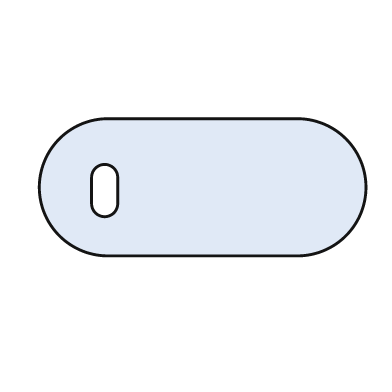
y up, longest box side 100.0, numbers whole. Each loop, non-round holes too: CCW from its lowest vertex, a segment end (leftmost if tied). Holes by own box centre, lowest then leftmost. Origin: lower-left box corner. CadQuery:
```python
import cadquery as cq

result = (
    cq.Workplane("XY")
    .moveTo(21.0, 0.0)
    .lineTo(79.0, 0.0)
    .threePointArc((100.0, 21.0), (79.0, 42.0))
    .lineTo(21.0, 42.0)
    .threePointArc((0.0, 21.0), (21.0, 0.0))
    .close()
    .moveTo(16.0, 16.0)
    .threePointArc((20.0, 12.0), (24.0, 16.0))
    .lineTo(24.0, 24.0)
    .threePointArc((20.0, 28.0), (16.0, 24.0))
    .close()
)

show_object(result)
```